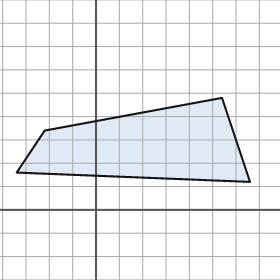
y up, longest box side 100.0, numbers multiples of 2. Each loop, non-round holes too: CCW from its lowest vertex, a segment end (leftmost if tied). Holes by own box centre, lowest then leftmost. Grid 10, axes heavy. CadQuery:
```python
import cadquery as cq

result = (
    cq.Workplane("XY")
    .moveTo(66.0, 12.0)
    .lineTo(54.0, 48.0)
    .lineTo(-22.0, 34.0)
    .lineTo(-34.0, 16.0)
    .close()
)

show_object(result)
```